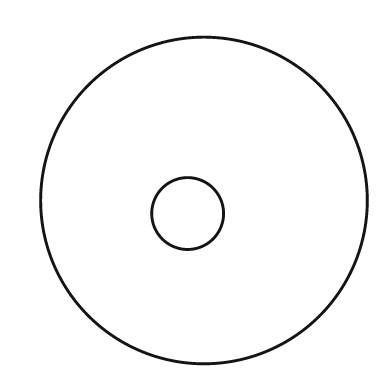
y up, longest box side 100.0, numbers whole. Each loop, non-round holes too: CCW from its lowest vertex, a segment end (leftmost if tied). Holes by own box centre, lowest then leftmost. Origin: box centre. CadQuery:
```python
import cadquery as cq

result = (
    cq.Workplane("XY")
    .moveTo(0.0, 0.0)
    .circle(50.0)
    .moveTo(-5.0, -4.0)
    .circle(11.0)
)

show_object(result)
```